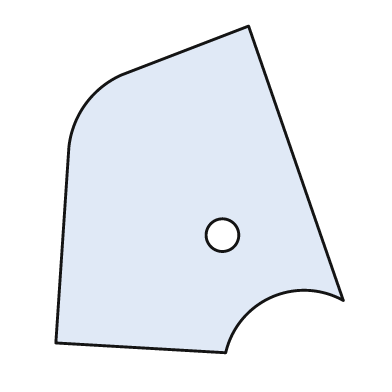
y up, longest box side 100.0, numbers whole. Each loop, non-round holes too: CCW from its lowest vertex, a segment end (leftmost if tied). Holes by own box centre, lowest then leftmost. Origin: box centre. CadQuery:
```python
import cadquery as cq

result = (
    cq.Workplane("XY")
    .moveTo(8.0, -50.0)
    .threePointArc((22.0, -33.0), (44.0, -34.0))
    .lineTo(15.0, 50.0)
    .lineTo(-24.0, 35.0)
    .threePointArc((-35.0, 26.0), (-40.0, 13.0))
    .lineTo(-44.0, -47.0)
    .close()
    .moveTo(7.0, -14.0)
    .circle(5.0)
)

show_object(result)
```